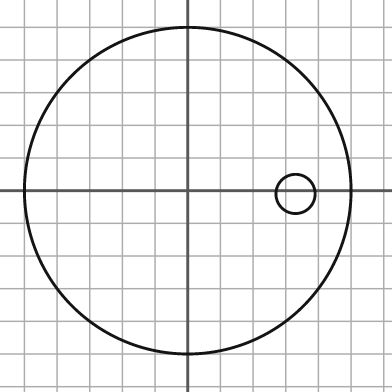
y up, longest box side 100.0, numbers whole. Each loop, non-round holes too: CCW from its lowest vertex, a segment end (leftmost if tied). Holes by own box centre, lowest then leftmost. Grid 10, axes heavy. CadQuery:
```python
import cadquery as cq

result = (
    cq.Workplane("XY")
    .moveTo(0.0, 0.0)
    .circle(50.0)
    .moveTo(33.0, -1.0)
    .circle(6.0)
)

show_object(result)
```